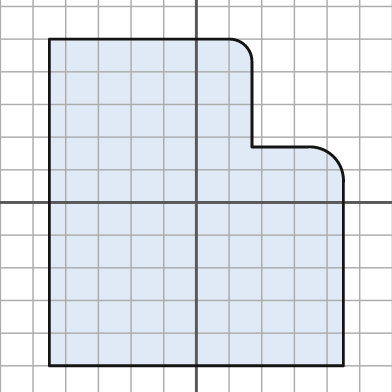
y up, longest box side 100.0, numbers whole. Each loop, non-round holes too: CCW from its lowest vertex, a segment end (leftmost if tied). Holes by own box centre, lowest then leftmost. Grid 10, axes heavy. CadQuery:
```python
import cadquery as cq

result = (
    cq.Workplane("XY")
    .moveTo(-45.0, -50.0)
    .lineTo(45.0, -50.0)
    .lineTo(45.0, 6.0)
    .threePointArc((42.0, 14.0), (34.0, 17.0))
    .lineTo(17.0, 17.0)
    .lineTo(17.0, 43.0)
    .threePointArc((15.0, 48.0), (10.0, 50.0))
    .lineTo(-45.0, 50.0)
    .close()
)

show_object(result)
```